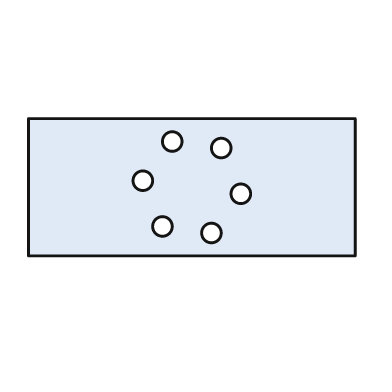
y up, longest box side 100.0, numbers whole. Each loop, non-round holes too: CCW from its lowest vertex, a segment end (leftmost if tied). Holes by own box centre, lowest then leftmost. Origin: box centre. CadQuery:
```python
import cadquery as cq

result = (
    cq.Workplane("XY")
    .moveTo(-50.0, -21.0)
    .lineTo(50.0, -21.0)
    .lineTo(50.0, 21.0)
    .lineTo(-50.0, 21.0)
    .close()
    .moveTo(6.0, -14.0)
    .circle(3.0)
    .moveTo(-9.0, -12.0)
    .circle(3.0)
    .moveTo(15.0, -2.0)
    .circle(3.0)
    .moveTo(-15.0, 2.0)
    .circle(3.0)
    .moveTo(9.0, 12.0)
    .circle(3.0)
    .moveTo(-6.0, 14.0)
    .circle(3.0)
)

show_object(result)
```